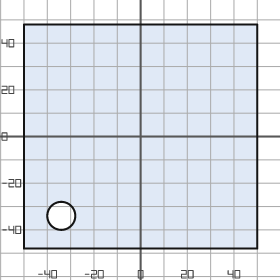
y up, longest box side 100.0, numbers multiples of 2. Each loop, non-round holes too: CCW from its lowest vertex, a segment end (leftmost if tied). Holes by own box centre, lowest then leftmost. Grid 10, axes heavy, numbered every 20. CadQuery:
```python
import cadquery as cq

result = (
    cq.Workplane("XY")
    .moveTo(-50.0, -48.0)
    .lineTo(50.0, -48.0)
    .lineTo(50.0, 48.0)
    .lineTo(-50.0, 48.0)
    .close()
    .moveTo(-34.0, -34.0)
    .circle(6.0)
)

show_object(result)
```